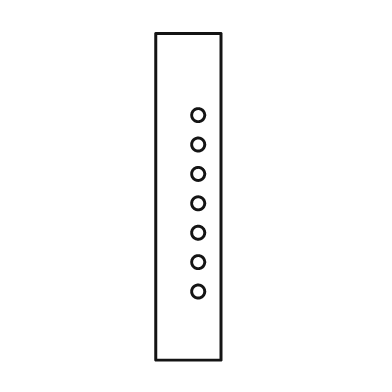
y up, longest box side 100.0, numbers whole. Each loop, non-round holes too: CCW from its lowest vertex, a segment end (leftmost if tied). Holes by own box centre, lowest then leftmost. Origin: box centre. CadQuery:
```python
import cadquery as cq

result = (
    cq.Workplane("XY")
    .moveTo(-10.0, -50.0)
    .lineTo(10.0, -50.0)
    .lineTo(10.0, 50.0)
    .lineTo(-10.0, 50.0)
    .close()
    .moveTo(3.0, -29.0)
    .circle(2.0)
    .moveTo(3.0, -20.0)
    .circle(2.0)
    .moveTo(3.0, -11.0)
    .circle(2.0)
    .moveTo(3.0, -2.0)
    .circle(2.0)
    .moveTo(3.0, 7.0)
    .circle(2.0)
    .moveTo(3.0, 16.0)
    .circle(2.0)
    .moveTo(3.0, 25.0)
    .circle(2.0)
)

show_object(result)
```